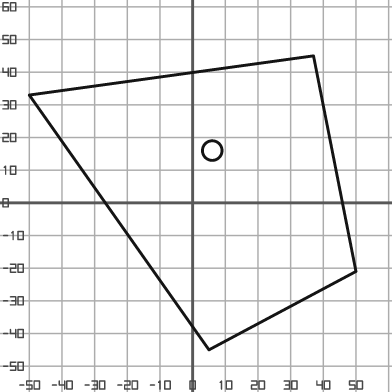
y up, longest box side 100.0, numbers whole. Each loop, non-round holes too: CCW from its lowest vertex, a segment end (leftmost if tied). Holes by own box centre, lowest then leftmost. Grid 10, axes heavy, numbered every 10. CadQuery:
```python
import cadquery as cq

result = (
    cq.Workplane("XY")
    .moveTo(5.0, -45.0)
    .lineTo(50.0, -21.0)
    .lineTo(37.0, 45.0)
    .lineTo(-50.0, 33.0)
    .close()
    .moveTo(6.0, 16.0)
    .circle(3.0)
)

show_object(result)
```